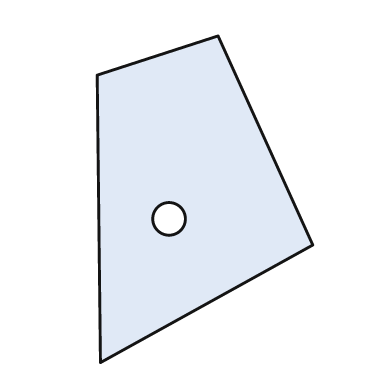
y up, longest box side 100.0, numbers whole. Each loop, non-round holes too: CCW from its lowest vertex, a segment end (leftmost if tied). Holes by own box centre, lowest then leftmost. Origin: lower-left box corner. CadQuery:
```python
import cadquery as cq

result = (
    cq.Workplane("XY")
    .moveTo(1.0, 0.0)
    .lineTo(66.0, 36.0)
    .lineTo(37.0, 100.0)
    .lineTo(0.0, 88.0)
    .close()
    .moveTo(22.0, 44.0)
    .circle(5.0)
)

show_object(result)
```